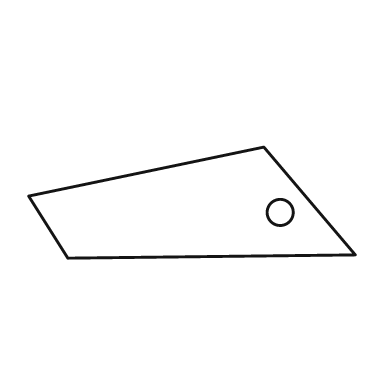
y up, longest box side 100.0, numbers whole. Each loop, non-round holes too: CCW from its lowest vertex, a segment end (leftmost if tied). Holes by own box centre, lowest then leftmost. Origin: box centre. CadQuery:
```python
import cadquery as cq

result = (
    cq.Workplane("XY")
    .moveTo(-38.0, -17.0)
    .lineTo(50.0, -16.0)
    .lineTo(22.0, 17.0)
    .lineTo(-50.0, 2.0)
    .close()
    .moveTo(27.0, -3.0)
    .circle(4.0)
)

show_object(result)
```